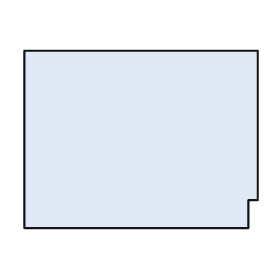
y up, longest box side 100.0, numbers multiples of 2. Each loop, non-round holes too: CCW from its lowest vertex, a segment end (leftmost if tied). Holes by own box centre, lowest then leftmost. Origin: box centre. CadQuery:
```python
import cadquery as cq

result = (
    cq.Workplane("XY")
    .moveTo(-50.0, -38.0)
    .lineTo(46.0, -38.0)
    .lineTo(46.0, -26.0)
    .lineTo(50.0, -26.0)
    .lineTo(50.0, 38.0)
    .lineTo(-50.0, 38.0)
    .close()
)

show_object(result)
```